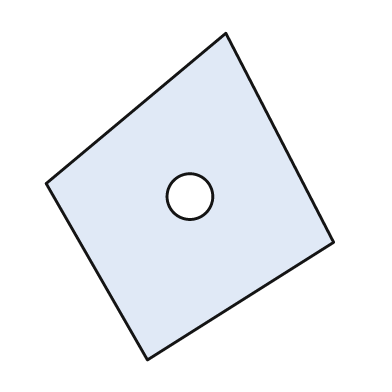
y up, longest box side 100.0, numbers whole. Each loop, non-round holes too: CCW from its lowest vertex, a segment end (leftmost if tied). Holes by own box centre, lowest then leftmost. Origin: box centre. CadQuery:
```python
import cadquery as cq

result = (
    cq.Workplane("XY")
    .moveTo(-13.0, -50.0)
    .lineTo(44.0, -14.0)
    .lineTo(11.0, 50.0)
    .lineTo(-44.0, 4.0)
    .close()
    .moveTo(0.0, 0.0)
    .circle(7.0)
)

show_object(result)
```